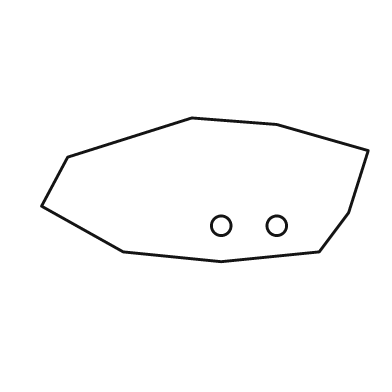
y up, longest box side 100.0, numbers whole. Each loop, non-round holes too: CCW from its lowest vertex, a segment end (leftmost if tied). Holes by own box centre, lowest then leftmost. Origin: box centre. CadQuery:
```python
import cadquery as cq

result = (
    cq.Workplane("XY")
    .moveTo(5.0, -22.0)
    .lineTo(35.0, -19.0)
    .lineTo(44.0, -7.0)
    .lineTo(50.0, 12.0)
    .lineTo(22.0, 20.0)
    .lineTo(-4.0, 22.0)
    .lineTo(-42.0, 10.0)
    .lineTo(-50.0, -5.0)
    .lineTo(-25.0, -19.0)
    .close()
    .moveTo(5.0, -11.0)
    .circle(3.0)
    .moveTo(22.0, -11.0)
    .circle(3.0)
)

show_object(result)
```